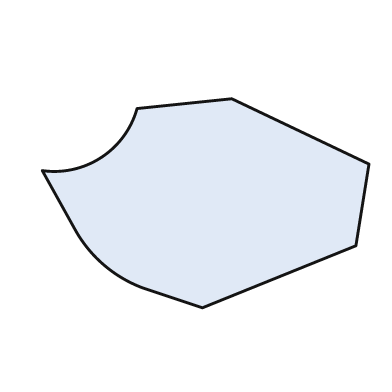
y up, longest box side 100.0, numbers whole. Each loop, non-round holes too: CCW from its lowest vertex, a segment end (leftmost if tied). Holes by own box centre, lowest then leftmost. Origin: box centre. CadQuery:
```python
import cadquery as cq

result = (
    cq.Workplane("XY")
    .moveTo(-1.0, -32.0)
    .lineTo(46.0, -13.0)
    .lineTo(50.0, 12.0)
    .lineTo(8.0, 32.0)
    .lineTo(-21.0, 29.0)
    .threePointArc((-32.0, 14.0), (-50.0, 10.0))
    .lineTo(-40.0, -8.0)
    .threePointArc((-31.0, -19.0), (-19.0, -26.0))
    .close()
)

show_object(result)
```